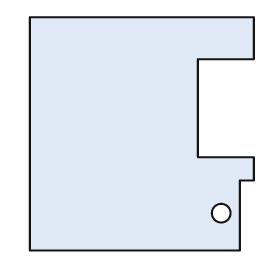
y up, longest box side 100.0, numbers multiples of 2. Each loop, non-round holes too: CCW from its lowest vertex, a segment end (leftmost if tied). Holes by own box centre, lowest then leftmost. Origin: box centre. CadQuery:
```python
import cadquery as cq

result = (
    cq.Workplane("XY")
    .moveTo(-48.0, -50.0)
    .lineTo(42.0, -50.0)
    .lineTo(42.0, -20.0)
    .lineTo(48.0, -20.0)
    .lineTo(48.0, -10.0)
    .lineTo(24.0, -10.0)
    .lineTo(24.0, 32.0)
    .lineTo(48.0, 32.0)
    .lineTo(48.0, 50.0)
    .lineTo(-48.0, 50.0)
    .close()
    .moveTo(34.0, -34.0)
    .circle(4.0)
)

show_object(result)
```